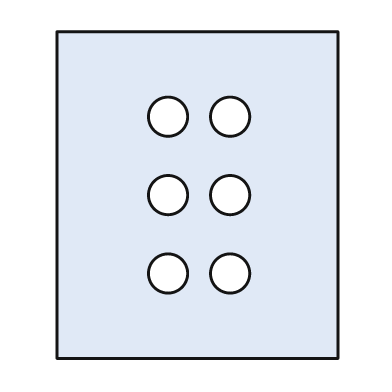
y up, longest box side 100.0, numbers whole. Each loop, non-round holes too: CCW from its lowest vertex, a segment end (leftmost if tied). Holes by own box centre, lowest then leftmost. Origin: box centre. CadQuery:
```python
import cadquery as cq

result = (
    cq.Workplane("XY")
    .moveTo(-43.0, -50.0)
    .lineTo(43.0, -50.0)
    .lineTo(43.0, 50.0)
    .lineTo(-43.0, 50.0)
    .close()
    .moveTo(-9.0, -24.0)
    .circle(6.0)
    .moveTo(10.0, -24.0)
    .circle(6.0)
    .moveTo(-9.0, 0.0)
    .circle(6.0)
    .moveTo(10.0, 0.0)
    .circle(6.0)
    .moveTo(-9.0, 24.0)
    .circle(6.0)
    .moveTo(10.0, 24.0)
    .circle(6.0)
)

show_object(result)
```